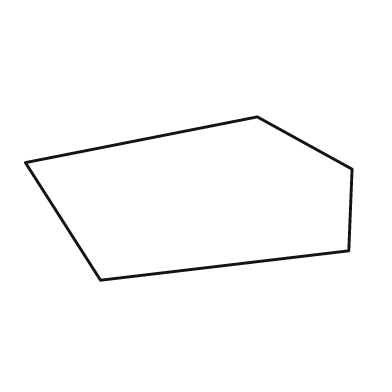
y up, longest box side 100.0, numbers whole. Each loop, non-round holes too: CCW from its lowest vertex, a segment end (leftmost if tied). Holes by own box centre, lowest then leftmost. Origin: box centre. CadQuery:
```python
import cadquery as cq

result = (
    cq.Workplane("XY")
    .moveTo(-27.0, -25.0)
    .lineTo(49.0, -16.0)
    .lineTo(50.0, 9.0)
    .lineTo(21.0, 25.0)
    .lineTo(-50.0, 11.0)
    .close()
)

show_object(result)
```